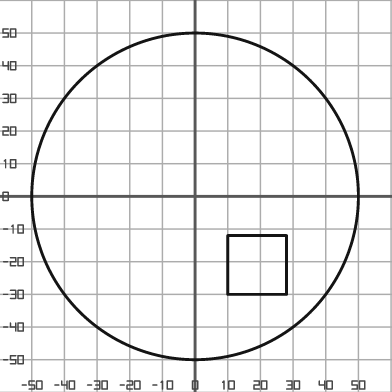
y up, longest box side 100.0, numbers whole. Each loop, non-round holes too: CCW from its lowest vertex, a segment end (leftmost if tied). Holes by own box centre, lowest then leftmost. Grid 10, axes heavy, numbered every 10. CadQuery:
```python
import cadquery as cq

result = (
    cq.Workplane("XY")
    .moveTo(0.0, 0.0)
    .circle(50.0)
    .moveTo(10.0, -30.0)
    .lineTo(28.0, -30.0)
    .lineTo(28.0, -12.0)
    .lineTo(10.0, -12.0)
    .close()
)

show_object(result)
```